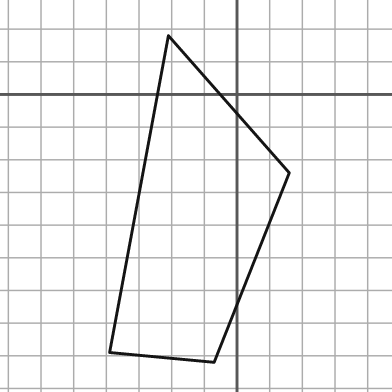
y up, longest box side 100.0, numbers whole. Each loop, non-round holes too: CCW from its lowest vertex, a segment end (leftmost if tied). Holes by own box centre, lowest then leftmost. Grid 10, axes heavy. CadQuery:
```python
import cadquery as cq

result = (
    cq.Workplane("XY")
    .moveTo(-7.0, -82.0)
    .lineTo(16.0, -24.0)
    .lineTo(-21.0, 18.0)
    .lineTo(-39.0, -79.0)
    .close()
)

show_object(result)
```